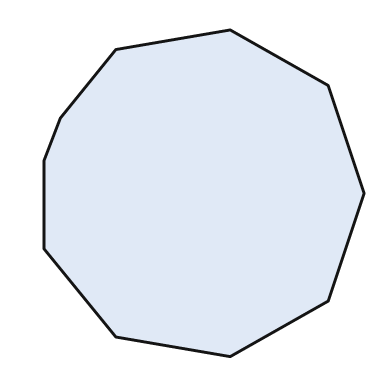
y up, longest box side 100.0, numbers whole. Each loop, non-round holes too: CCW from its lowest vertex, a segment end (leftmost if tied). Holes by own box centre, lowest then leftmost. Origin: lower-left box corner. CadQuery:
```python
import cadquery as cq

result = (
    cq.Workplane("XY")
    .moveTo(57.0, 0.0)
    .lineTo(87.0, 17.0)
    .lineTo(98.0, 50.0)
    .lineTo(87.0, 83.0)
    .lineTo(57.0, 100.0)
    .lineTo(22.0, 94.0)
    .lineTo(5.0, 73.0)
    .lineTo(0.0, 60.0)
    .lineTo(0.0, 33.0)
    .lineTo(22.0, 6.0)
    .close()
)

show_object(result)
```